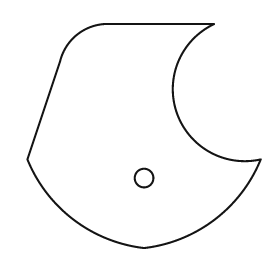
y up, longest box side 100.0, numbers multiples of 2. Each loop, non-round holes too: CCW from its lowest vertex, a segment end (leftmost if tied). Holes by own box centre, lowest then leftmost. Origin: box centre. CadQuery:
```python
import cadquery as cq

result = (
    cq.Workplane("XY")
    .moveTo(0.0, -48.0)
    .threePointArc((30.0, -36.0), (50.0, -10.0))
    .threePointArc((14.0, 10.0), (30.0, 48.0))
    .lineTo(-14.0, 48.0)
    .threePointArc((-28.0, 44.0), (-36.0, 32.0))
    .lineTo(-50.0, -10.0)
    .threePointArc((-30.0, -36.0), (0.0, -48.0))
    .close()
    .moveTo(0.0, -18.0)
    .circle(4.0)
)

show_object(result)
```